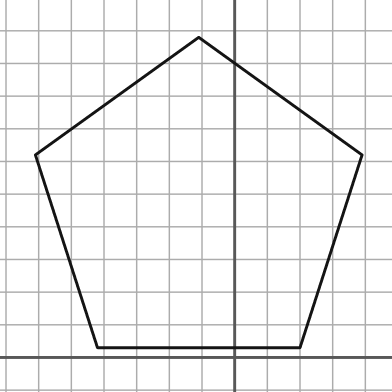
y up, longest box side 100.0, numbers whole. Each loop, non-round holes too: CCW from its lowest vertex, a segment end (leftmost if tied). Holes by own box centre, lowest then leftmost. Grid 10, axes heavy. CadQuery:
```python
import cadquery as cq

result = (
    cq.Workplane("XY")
    .moveTo(-42.0, 3.0)
    .lineTo(20.0, 3.0)
    .lineTo(39.0, 62.0)
    .lineTo(-11.0, 98.0)
    .lineTo(-61.0, 62.0)
    .close()
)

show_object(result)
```